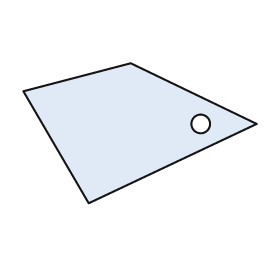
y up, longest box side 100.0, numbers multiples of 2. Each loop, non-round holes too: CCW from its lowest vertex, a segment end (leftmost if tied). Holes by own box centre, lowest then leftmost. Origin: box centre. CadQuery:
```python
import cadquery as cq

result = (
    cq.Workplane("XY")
    .moveTo(-22.0, -30.0)
    .lineTo(50.0, 4.0)
    .lineTo(-4.0, 30.0)
    .lineTo(-50.0, 18.0)
    .close()
    .moveTo(26.0, 4.0)
    .circle(4.0)
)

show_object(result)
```